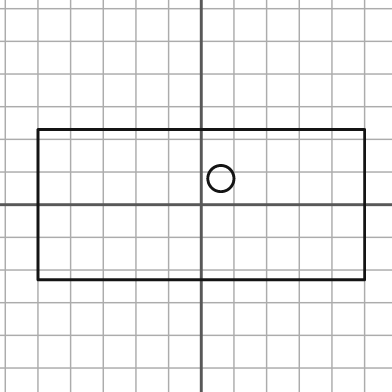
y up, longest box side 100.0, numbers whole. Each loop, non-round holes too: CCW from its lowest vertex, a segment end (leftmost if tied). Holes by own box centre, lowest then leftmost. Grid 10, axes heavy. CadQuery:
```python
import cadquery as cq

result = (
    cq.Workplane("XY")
    .moveTo(-50.0, -23.0)
    .lineTo(50.0, -23.0)
    .lineTo(50.0, 23.0)
    .lineTo(-50.0, 23.0)
    .close()
    .moveTo(6.0, 8.0)
    .circle(4.0)
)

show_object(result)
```